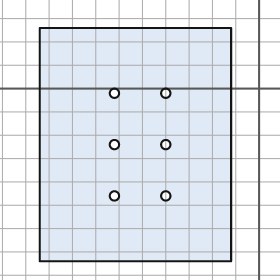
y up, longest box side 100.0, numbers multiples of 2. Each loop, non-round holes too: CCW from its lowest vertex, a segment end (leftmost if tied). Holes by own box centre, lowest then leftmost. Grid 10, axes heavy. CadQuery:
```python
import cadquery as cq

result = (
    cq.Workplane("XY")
    .moveTo(-94.0, -74.0)
    .lineTo(-12.0, -74.0)
    .lineTo(-12.0, 26.0)
    .lineTo(-94.0, 26.0)
    .close()
    .moveTo(-62.0, -46.0)
    .circle(2.0)
    .moveTo(-40.0, -46.0)
    .circle(2.0)
    .moveTo(-62.0, -24.0)
    .circle(2.0)
    .moveTo(-40.0, -24.0)
    .circle(2.0)
    .moveTo(-62.0, -2.0)
    .circle(2.0)
    .moveTo(-40.0, -2.0)
    .circle(2.0)
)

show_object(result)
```